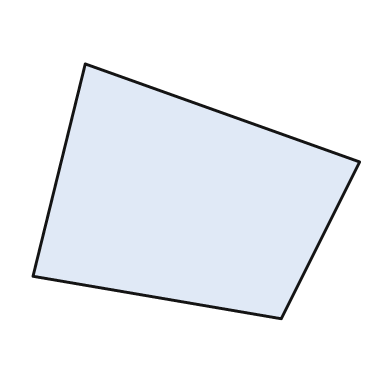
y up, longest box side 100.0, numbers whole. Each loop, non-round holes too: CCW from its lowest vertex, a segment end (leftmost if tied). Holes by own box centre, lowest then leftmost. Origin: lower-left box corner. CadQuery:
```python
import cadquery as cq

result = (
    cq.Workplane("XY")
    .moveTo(76.0, 0.0)
    .lineTo(100.0, 48.0)
    .lineTo(16.0, 78.0)
    .lineTo(0.0, 13.0)
    .close()
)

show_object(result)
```